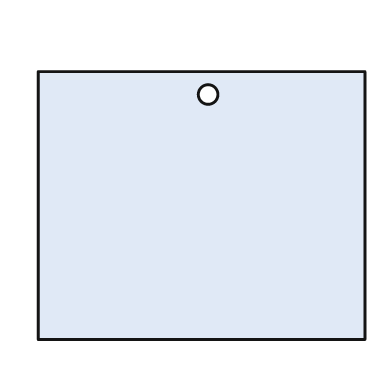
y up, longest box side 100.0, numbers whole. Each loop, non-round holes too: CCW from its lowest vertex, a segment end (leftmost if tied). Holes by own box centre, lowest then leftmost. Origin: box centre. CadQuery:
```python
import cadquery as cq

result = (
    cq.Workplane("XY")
    .moveTo(-50.0, -41.0)
    .lineTo(50.0, -41.0)
    .lineTo(50.0, 41.0)
    .lineTo(-50.0, 41.0)
    .close()
    .moveTo(2.0, 34.0)
    .circle(3.0)
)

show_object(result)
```